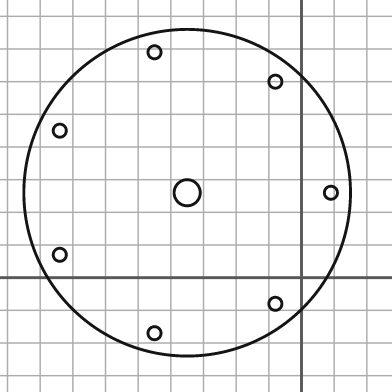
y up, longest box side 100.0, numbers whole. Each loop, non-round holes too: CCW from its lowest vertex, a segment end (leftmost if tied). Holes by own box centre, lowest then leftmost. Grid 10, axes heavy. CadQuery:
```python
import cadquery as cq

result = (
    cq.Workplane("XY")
    .moveTo(-35.0, 26.0)
    .circle(50.0)
    .moveTo(-45.0, -17.0)
    .circle(2.0)
    .moveTo(-8.0, -8.0)
    .circle(2.0)
    .moveTo(-74.0, 7.0)
    .circle(2.0)
    .moveTo(-35.0, 26.0)
    .circle(4.0)
    .moveTo(9.0, 26.0)
    .circle(2.0)
    .moveTo(-74.0, 45.0)
    .circle(2.0)
    .moveTo(-8.0, 60.0)
    .circle(2.0)
    .moveTo(-45.0, 69.0)
    .circle(2.0)
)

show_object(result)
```